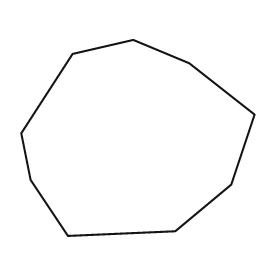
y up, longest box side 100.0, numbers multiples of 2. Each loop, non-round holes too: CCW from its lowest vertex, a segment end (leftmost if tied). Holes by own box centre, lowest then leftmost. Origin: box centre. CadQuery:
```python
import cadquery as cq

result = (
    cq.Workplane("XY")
    .moveTo(-30.0, -42.0)
    .lineTo(16.0, -40.0)
    .lineTo(40.0, -20.0)
    .lineTo(50.0, 10.0)
    .lineTo(22.0, 32.0)
    .lineTo(-2.0, 42.0)
    .lineTo(-28.0, 36.0)
    .lineTo(-50.0, 2.0)
    .lineTo(-46.0, -18.0)
    .close()
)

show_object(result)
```